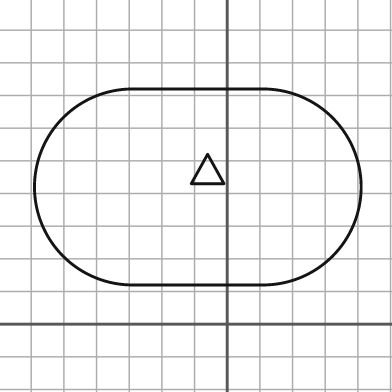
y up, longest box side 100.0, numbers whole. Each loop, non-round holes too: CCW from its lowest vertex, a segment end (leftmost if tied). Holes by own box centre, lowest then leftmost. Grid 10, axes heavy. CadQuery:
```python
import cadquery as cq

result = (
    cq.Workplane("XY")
    .moveTo(-29.0, 12.0)
    .lineTo(11.0, 12.0)
    .threePointArc((41.0, 42.0), (11.0, 72.0))
    .lineTo(-29.0, 72.0)
    .threePointArc((-59.0, 42.0), (-29.0, 12.0))
    .close()
    .moveTo(-11.0, 43.0)
    .lineTo(-1.0, 43.0)
    .lineTo(-6.0, 52.0)
    .close()
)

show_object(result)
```